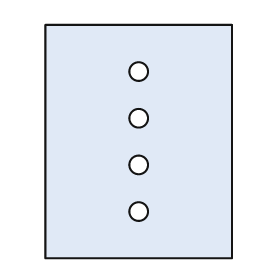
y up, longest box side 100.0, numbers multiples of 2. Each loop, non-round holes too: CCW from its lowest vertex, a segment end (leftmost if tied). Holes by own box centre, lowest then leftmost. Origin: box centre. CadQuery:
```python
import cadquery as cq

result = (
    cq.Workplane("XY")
    .moveTo(-40.0, -50.0)
    .lineTo(40.0, -50.0)
    .lineTo(40.0, 50.0)
    .lineTo(-40.0, 50.0)
    .close()
    .moveTo(0.0, -30.0)
    .circle(4.0)
    .moveTo(0.0, -10.0)
    .circle(4.0)
    .moveTo(0.0, 10.0)
    .circle(4.0)
    .moveTo(0.0, 30.0)
    .circle(4.0)
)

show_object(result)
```